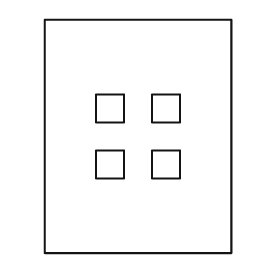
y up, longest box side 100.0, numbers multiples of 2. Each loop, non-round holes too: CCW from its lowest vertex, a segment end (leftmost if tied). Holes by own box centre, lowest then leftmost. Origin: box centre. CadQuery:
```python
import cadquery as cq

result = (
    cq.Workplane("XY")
    .moveTo(-40.0, -50.0)
    .lineTo(40.0, -50.0)
    .lineTo(40.0, 50.0)
    .lineTo(-40.0, 50.0)
    .close()
    .moveTo(-18.0, -18.0)
    .lineTo(-6.0, -18.0)
    .lineTo(-6.0, -6.0)
    .lineTo(-18.0, -6.0)
    .close()
    .moveTo(6.0, -18.0)
    .lineTo(18.0, -18.0)
    .lineTo(18.0, -6.0)
    .lineTo(6.0, -6.0)
    .close()
    .moveTo(-18.0, 6.0)
    .lineTo(-6.0, 6.0)
    .lineTo(-6.0, 18.0)
    .lineTo(-18.0, 18.0)
    .close()
    .moveTo(6.0, 6.0)
    .lineTo(18.0, 6.0)
    .lineTo(18.0, 18.0)
    .lineTo(6.0, 18.0)
    .close()
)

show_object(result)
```